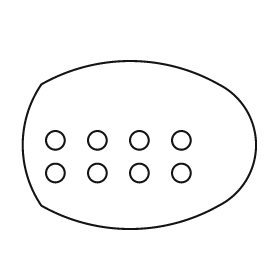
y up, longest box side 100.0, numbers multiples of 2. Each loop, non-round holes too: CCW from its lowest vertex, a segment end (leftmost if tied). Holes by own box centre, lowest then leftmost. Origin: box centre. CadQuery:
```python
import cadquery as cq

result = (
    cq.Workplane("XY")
    .moveTo(-42.0, -26.0)
    .threePointArc((-4.0, -36.0), (34.0, -26.0))
    .threePointArc((50.0, 0.0), (34.0, 26.0))
    .threePointArc((-4.0, 36.0), (-42.0, 26.0))
    .threePointArc((-50.0, 0.0), (-42.0, -26.0))
    .close()
    .moveTo(-36.0, -12.0)
    .circle(4.0)
    .moveTo(-18.0, -12.0)
    .circle(4.0)
    .moveTo(0.0, -12.0)
    .circle(4.0)
    .moveTo(18.0, -12.0)
    .circle(4.0)
    .moveTo(-36.0, 2.0)
    .circle(4.0)
    .moveTo(-18.0, 2.0)
    .circle(4.0)
    .moveTo(0.0, 2.0)
    .circle(4.0)
    .moveTo(18.0, 2.0)
    .circle(4.0)
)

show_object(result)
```